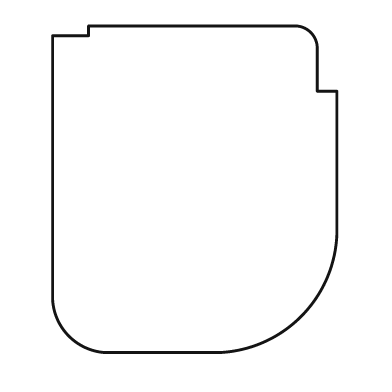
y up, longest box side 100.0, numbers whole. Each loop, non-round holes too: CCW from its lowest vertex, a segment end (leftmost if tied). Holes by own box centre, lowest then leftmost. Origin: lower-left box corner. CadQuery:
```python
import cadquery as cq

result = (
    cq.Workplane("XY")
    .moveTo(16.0, 0.0)
    .lineTo(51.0, 0.0)
    .threePointArc((76.0, 11.0), (87.0, 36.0))
    .lineTo(87.0, 80.0)
    .lineTo(81.0, 80.0)
    .lineTo(81.0, 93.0)
    .threePointArc((79.0, 98.0), (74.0, 100.0))
    .lineTo(11.0, 100.0)
    .lineTo(11.0, 97.0)
    .lineTo(0.0, 97.0)
    .lineTo(0.0, 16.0)
    .threePointArc((5.0, 5.0), (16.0, 0.0))
    .close()
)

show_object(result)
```